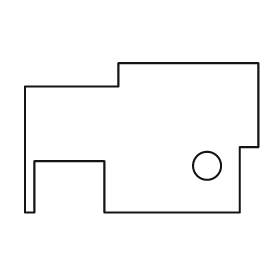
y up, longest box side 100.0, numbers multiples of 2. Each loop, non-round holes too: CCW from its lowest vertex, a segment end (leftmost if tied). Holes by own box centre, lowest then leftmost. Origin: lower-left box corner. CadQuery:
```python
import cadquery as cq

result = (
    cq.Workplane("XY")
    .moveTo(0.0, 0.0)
    .lineTo(4.0, 0.0)
    .lineTo(4.0, 22.0)
    .lineTo(34.0, 22.0)
    .lineTo(34.0, 0.0)
    .lineTo(92.0, 0.0)
    .lineTo(92.0, 28.0)
    .lineTo(100.0, 28.0)
    .lineTo(100.0, 64.0)
    .lineTo(40.0, 64.0)
    .lineTo(40.0, 54.0)
    .lineTo(0.0, 54.0)
    .close()
    .moveTo(78.0, 20.0)
    .circle(6.0)
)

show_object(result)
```